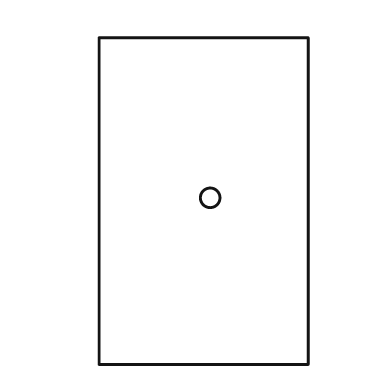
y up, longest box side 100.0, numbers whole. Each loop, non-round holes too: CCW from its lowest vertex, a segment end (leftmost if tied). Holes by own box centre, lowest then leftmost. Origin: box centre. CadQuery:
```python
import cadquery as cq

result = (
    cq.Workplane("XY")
    .moveTo(-32.0, -50.0)
    .lineTo(32.0, -50.0)
    .lineTo(32.0, 50.0)
    .lineTo(-32.0, 50.0)
    .close()
    .moveTo(2.0, 1.0)
    .circle(3.0)
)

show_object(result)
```